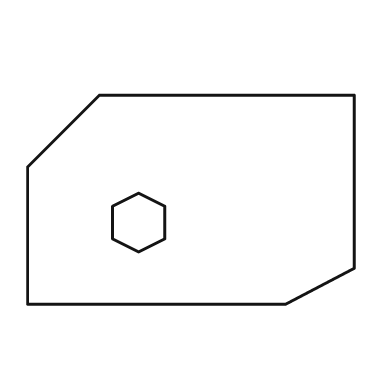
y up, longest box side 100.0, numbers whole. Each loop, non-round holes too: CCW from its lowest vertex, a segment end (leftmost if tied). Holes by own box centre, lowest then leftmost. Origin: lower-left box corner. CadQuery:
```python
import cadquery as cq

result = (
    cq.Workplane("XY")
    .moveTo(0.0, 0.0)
    .lineTo(79.0, 0.0)
    .lineTo(100.0, 11.0)
    .lineTo(100.0, 64.0)
    .lineTo(22.0, 64.0)
    .lineTo(0.0, 42.0)
    .close()
    .moveTo(34.0, 16.0)
    .lineTo(42.0, 20.0)
    .lineTo(42.0, 30.0)
    .lineTo(34.0, 34.0)
    .lineTo(26.0, 30.0)
    .lineTo(26.0, 20.0)
    .close()
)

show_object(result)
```